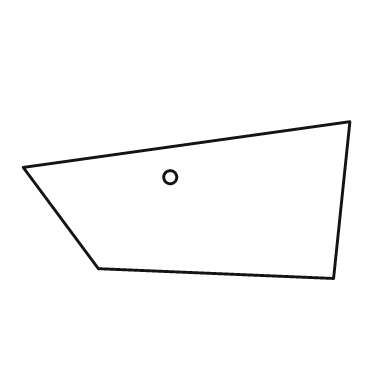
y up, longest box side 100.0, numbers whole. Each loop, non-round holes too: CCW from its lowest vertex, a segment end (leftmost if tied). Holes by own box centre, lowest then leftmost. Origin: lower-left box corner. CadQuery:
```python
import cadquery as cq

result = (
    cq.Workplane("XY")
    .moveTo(95.0, 0.0)
    .lineTo(100.0, 48.0)
    .lineTo(0.0, 34.0)
    .lineTo(23.0, 3.0)
    .close()
    .moveTo(45.0, 31.0)
    .circle(2.0)
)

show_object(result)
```